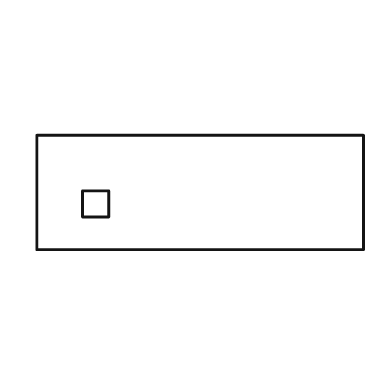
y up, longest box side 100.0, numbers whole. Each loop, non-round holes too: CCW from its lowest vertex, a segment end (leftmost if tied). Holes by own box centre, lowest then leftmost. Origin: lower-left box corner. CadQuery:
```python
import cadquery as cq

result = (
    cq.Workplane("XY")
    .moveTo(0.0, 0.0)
    .lineTo(100.0, 0.0)
    .lineTo(100.0, 35.0)
    .lineTo(0.0, 35.0)
    .close()
    .moveTo(14.0, 10.0)
    .lineTo(22.0, 10.0)
    .lineTo(22.0, 18.0)
    .lineTo(14.0, 18.0)
    .close()
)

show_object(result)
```